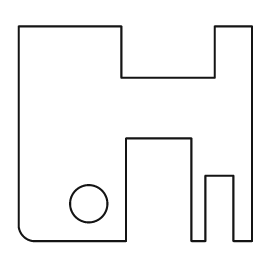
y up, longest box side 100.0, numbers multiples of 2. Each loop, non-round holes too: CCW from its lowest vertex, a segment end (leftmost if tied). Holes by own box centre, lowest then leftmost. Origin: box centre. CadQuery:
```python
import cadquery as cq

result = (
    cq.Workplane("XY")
    .moveTo(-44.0, -46.0)
    .lineTo(-4.0, -46.0)
    .lineTo(-4.0, -2.0)
    .lineTo(24.0, -2.0)
    .lineTo(24.0, -46.0)
    .lineTo(30.0, -46.0)
    .lineTo(30.0, -18.0)
    .lineTo(42.0, -18.0)
    .lineTo(42.0, -46.0)
    .lineTo(50.0, -46.0)
    .lineTo(50.0, 46.0)
    .lineTo(34.0, 46.0)
    .lineTo(34.0, 24.0)
    .lineTo(-6.0, 24.0)
    .lineTo(-6.0, 46.0)
    .lineTo(-50.0, 46.0)
    .lineTo(-50.0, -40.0)
    .threePointArc((-48.0, -44.0), (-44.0, -46.0))
    .close()
    .moveTo(-20.0, -30.0)
    .circle(8.0)
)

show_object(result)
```